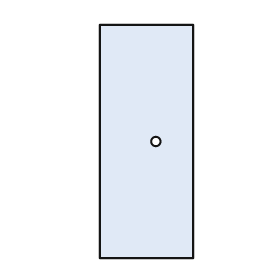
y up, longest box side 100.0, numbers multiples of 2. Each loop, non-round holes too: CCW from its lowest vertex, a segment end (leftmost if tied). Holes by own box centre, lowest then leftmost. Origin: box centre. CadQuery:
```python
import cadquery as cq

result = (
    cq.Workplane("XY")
    .moveTo(-20.0, -50.0)
    .lineTo(20.0, -50.0)
    .lineTo(20.0, 50.0)
    .lineTo(-20.0, 50.0)
    .close()
    .moveTo(4.0, 0.0)
    .circle(2.0)
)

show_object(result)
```